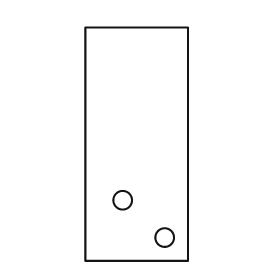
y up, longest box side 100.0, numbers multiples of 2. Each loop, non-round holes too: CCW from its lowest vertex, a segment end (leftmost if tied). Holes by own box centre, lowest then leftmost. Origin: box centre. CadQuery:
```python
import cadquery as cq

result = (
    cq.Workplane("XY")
    .moveTo(-22.0, -50.0)
    .lineTo(22.0, -50.0)
    .lineTo(22.0, 50.0)
    .lineTo(-22.0, 50.0)
    .close()
    .moveTo(12.0, -40.0)
    .circle(4.0)
    .moveTo(-6.0, -24.0)
    .circle(4.0)
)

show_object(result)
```